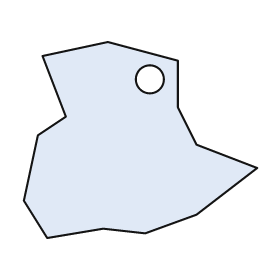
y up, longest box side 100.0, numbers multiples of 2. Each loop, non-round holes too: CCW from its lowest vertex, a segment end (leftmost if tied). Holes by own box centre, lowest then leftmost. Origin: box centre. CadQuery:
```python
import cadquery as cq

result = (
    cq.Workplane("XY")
    .moveTo(-40.0, -42.0)
    .lineTo(-16.0, -38.0)
    .lineTo(2.0, -40.0)
    .lineTo(24.0, -32.0)
    .lineTo(50.0, -12.0)
    .lineTo(24.0, -2.0)
    .lineTo(16.0, 14.0)
    .lineTo(16.0, 34.0)
    .lineTo(-14.0, 42.0)
    .lineTo(-42.0, 36.0)
    .lineTo(-32.0, 10.0)
    .lineTo(-44.0, 2.0)
    .lineTo(-50.0, -26.0)
    .close()
    .moveTo(4.0, 26.0)
    .circle(6.0)
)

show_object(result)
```